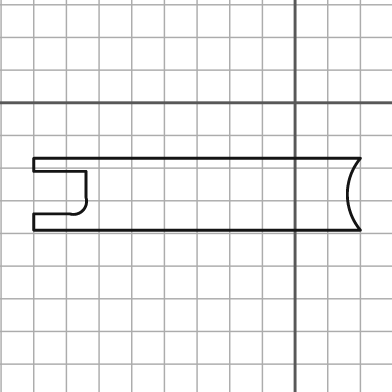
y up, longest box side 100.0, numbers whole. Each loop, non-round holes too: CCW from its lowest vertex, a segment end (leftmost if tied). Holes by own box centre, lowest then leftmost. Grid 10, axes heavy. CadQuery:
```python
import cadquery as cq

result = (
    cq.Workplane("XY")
    .moveTo(-80.0, -39.0)
    .lineTo(20.0, -39.0)
    .threePointArc((16.0, -28.0), (20.0, -17.0))
    .lineTo(-80.0, -17.0)
    .lineTo(-80.0, -21.0)
    .lineTo(-64.0, -21.0)
    .lineTo(-64.0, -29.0)
    .threePointArc((-65.0, -33.0), (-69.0, -34.0))
    .lineTo(-80.0, -34.0)
    .close()
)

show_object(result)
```